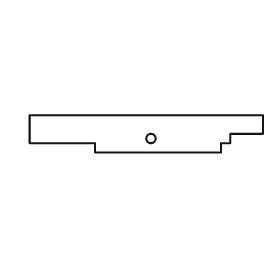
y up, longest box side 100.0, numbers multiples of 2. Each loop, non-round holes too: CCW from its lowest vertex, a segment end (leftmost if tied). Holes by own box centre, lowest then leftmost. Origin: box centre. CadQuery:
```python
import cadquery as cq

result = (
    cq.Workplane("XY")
    .moveTo(-22.0, -8.0)
    .lineTo(32.0, -8.0)
    .lineTo(32.0, -4.0)
    .lineTo(36.0, -4.0)
    .lineTo(36.0, 0.0)
    .lineTo(50.0, 0.0)
    .lineTo(50.0, 8.0)
    .lineTo(-50.0, 8.0)
    .lineTo(-50.0, -4.0)
    .lineTo(-22.0, -4.0)
    .close()
    .moveTo(2.0, -2.0)
    .circle(2.0)
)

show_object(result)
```